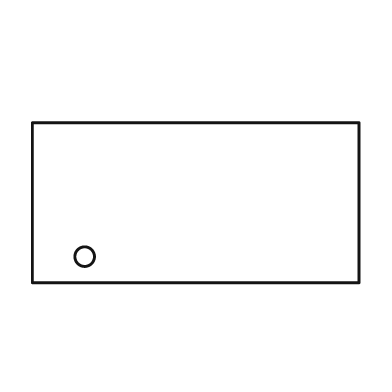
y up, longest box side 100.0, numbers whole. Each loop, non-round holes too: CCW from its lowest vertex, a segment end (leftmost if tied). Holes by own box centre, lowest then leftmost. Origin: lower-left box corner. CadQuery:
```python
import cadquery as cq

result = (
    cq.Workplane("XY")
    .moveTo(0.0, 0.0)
    .lineTo(100.0, 0.0)
    .lineTo(100.0, 49.0)
    .lineTo(0.0, 49.0)
    .close()
    .moveTo(16.0, 8.0)
    .circle(3.0)
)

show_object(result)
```